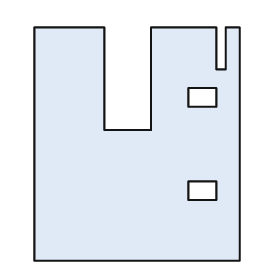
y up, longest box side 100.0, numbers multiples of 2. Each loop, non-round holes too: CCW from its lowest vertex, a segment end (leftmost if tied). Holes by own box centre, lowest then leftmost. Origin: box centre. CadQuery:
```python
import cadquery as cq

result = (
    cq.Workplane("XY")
    .moveTo(-44.0, -50.0)
    .lineTo(44.0, -50.0)
    .lineTo(44.0, 50.0)
    .lineTo(38.0, 50.0)
    .lineTo(38.0, 32.0)
    .lineTo(34.0, 32.0)
    .lineTo(34.0, 50.0)
    .lineTo(6.0, 50.0)
    .lineTo(6.0, 6.0)
    .lineTo(-14.0, 6.0)
    .lineTo(-14.0, 50.0)
    .lineTo(-44.0, 50.0)
    .close()
    .moveTo(22.0, -24.0)
    .lineTo(34.0, -24.0)
    .lineTo(34.0, -16.0)
    .lineTo(22.0, -16.0)
    .close()
    .moveTo(22.0, 16.0)
    .lineTo(34.0, 16.0)
    .lineTo(34.0, 24.0)
    .lineTo(22.0, 24.0)
    .close()
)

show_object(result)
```